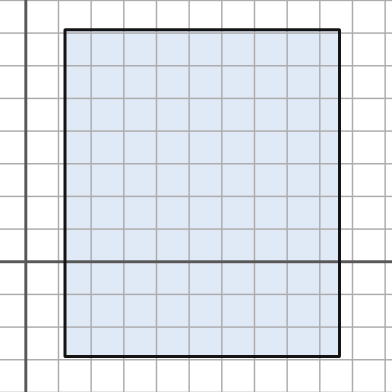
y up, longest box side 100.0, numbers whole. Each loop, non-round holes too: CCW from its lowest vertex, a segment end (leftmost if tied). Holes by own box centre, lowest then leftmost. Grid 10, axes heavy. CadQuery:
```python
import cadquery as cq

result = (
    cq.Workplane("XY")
    .moveTo(12.0, -29.0)
    .lineTo(96.0, -29.0)
    .lineTo(96.0, 71.0)
    .lineTo(12.0, 71.0)
    .close()
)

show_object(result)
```